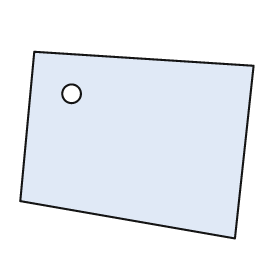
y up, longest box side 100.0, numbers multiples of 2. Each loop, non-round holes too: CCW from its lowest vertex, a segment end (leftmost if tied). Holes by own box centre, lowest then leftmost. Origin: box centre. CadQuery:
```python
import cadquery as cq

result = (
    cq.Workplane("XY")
    .moveTo(42.0, -40.0)
    .lineTo(50.0, 34.0)
    .lineTo(-44.0, 40.0)
    .lineTo(-50.0, -24.0)
    .close()
    .moveTo(-28.0, 22.0)
    .circle(4.0)
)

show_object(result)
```